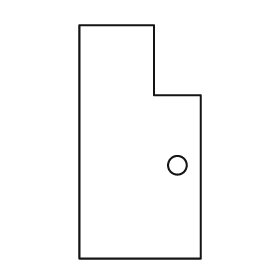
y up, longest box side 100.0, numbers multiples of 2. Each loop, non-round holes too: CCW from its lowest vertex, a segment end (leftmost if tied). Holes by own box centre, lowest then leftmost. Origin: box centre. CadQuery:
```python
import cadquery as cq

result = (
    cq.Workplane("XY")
    .moveTo(-26.0, -50.0)
    .lineTo(26.0, -50.0)
    .lineTo(26.0, 20.0)
    .lineTo(6.0, 20.0)
    .lineTo(6.0, 50.0)
    .lineTo(-26.0, 50.0)
    .close()
    .moveTo(16.0, -10.0)
    .circle(4.0)
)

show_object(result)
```